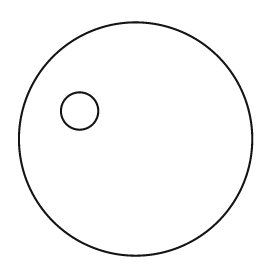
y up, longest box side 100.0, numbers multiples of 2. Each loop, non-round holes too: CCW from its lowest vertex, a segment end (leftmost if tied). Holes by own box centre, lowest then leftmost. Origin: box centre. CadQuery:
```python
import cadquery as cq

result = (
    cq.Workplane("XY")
    .moveTo(0.0, 0.0)
    .circle(50.0)
    .moveTo(-24.0, 12.0)
    .circle(8.0)
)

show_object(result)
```